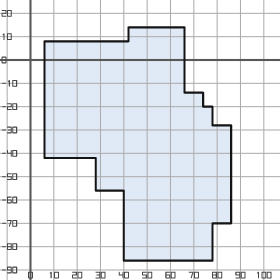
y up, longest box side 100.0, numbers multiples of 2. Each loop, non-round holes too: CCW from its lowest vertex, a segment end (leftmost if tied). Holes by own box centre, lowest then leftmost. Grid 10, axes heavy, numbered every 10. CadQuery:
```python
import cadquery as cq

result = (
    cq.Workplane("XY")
    .moveTo(40.0, -86.0)
    .lineTo(78.0, -86.0)
    .lineTo(78.0, -70.0)
    .lineTo(86.0, -70.0)
    .lineTo(86.0, -28.0)
    .lineTo(78.0, -28.0)
    .lineTo(78.0, -20.0)
    .lineTo(74.0, -20.0)
    .lineTo(74.0, -14.0)
    .lineTo(66.0, -14.0)
    .lineTo(66.0, 14.0)
    .lineTo(42.0, 14.0)
    .lineTo(42.0, 8.0)
    .lineTo(6.0, 8.0)
    .lineTo(6.0, -42.0)
    .lineTo(28.0, -42.0)
    .lineTo(28.0, -56.0)
    .lineTo(40.0, -56.0)
    .close()
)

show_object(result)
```